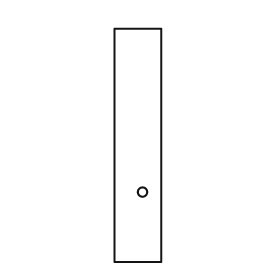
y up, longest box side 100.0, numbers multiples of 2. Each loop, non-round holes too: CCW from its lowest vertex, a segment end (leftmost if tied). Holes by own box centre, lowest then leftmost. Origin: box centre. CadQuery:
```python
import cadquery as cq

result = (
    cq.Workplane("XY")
    .moveTo(-10.0, -50.0)
    .lineTo(10.0, -50.0)
    .lineTo(10.0, 50.0)
    .lineTo(-10.0, 50.0)
    .close()
    .moveTo(2.0, -20.0)
    .circle(2.0)
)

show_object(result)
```